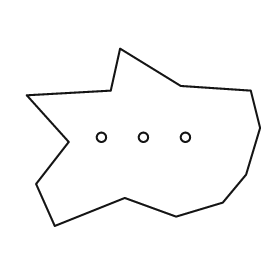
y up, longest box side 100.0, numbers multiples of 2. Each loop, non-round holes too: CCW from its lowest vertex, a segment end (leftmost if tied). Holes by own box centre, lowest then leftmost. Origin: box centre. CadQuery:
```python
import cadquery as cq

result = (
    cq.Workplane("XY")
    .moveTo(-38.0, -38.0)
    .lineTo(-8.0, -26.0)
    .lineTo(14.0, -34.0)
    .lineTo(34.0, -28.0)
    .lineTo(44.0, -16.0)
    .lineTo(50.0, 4.0)
    .lineTo(46.0, 20.0)
    .lineTo(16.0, 22.0)
    .lineTo(-10.0, 38.0)
    .lineTo(-14.0, 20.0)
    .lineTo(-50.0, 18.0)
    .lineTo(-32.0, -2.0)
    .lineTo(-46.0, -20.0)
    .close()
    .moveTo(-18.0, 0.0)
    .circle(2.0)
    .moveTo(0.0, 0.0)
    .circle(2.0)
    .moveTo(18.0, 0.0)
    .circle(2.0)
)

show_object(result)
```